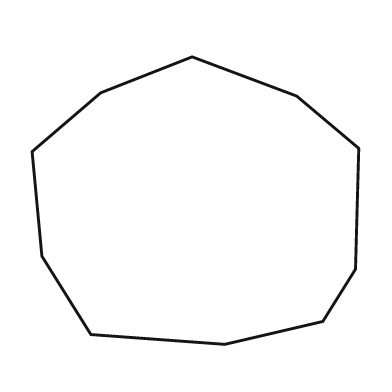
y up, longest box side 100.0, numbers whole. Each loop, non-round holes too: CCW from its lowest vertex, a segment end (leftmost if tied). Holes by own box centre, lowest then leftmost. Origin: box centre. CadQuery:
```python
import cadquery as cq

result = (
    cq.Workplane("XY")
    .moveTo(9.0, -44.0)
    .lineTo(39.0, -37.0)
    .lineTo(49.0, -21.0)
    .lineTo(50.0, 16.0)
    .lineTo(31.0, 32.0)
    .lineTo(-1.0, 44.0)
    .lineTo(-29.0, 33.0)
    .lineTo(-50.0, 15.0)
    .lineTo(-47.0, -17.0)
    .lineTo(-32.0, -41.0)
    .close()
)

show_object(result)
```